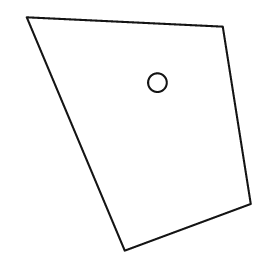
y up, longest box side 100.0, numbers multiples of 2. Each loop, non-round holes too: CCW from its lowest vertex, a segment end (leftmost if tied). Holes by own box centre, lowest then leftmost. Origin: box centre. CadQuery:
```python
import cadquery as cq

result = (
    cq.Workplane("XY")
    .moveTo(-6.0, -50.0)
    .lineTo(48.0, -30.0)
    .lineTo(36.0, 46.0)
    .lineTo(-48.0, 50.0)
    .close()
    .moveTo(8.0, 22.0)
    .circle(4.0)
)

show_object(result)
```